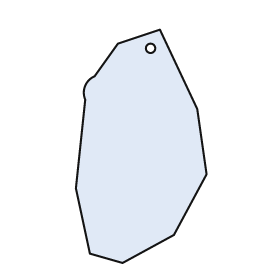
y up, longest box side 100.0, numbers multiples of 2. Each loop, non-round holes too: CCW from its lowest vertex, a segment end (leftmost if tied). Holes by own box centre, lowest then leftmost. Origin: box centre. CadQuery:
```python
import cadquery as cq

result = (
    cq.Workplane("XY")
    .moveTo(-8.0, -50.0)
    .lineTo(14.0, -38.0)
    .lineTo(28.0, -12.0)
    .lineTo(24.0, 16.0)
    .lineTo(8.0, 50.0)
    .lineTo(-10.0, 44.0)
    .lineTo(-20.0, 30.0)
    .threePointArc((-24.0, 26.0), (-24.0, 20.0))
    .lineTo(-28.0, -18.0)
    .lineTo(-22.0, -46.0)
    .close()
    .moveTo(4.0, 42.0)
    .circle(2.0)
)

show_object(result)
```